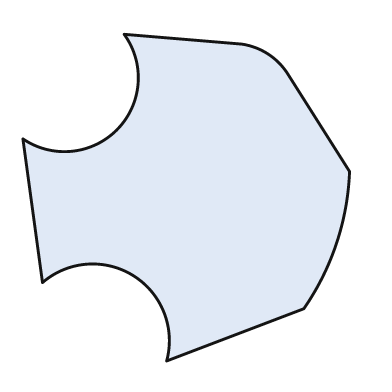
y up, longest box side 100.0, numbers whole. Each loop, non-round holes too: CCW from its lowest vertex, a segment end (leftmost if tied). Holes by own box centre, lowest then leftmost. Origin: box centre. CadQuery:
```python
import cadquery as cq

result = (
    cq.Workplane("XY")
    .moveTo(-6.0, -50.0)
    .lineTo(36.0, -34.0)
    .threePointArc((46.0, -14.0), (50.0, 8.0))
    .lineTo(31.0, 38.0)
    .threePointArc((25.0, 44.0), (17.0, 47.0))
    .lineTo(-19.0, 50.0)
    .threePointArc((-21.0, 21.0), (-50.0, 18.0))
    .lineTo(-44.0, -26.0)
    .threePointArc((-16.0, -24.0), (-6.0, -50.0))
    .close()
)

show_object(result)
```